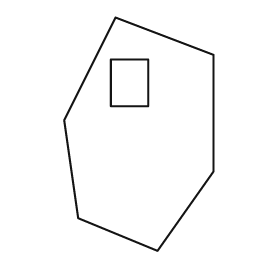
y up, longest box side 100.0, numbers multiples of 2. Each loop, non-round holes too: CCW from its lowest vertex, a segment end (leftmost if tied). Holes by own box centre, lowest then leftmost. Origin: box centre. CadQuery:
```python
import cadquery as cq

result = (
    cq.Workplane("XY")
    .moveTo(8.0, -50.0)
    .lineTo(32.0, -16.0)
    .lineTo(32.0, 34.0)
    .lineTo(-10.0, 50.0)
    .lineTo(-32.0, 6.0)
    .lineTo(-26.0, -36.0)
    .close()
    .moveTo(-12.0, 12.0)
    .lineTo(4.0, 12.0)
    .lineTo(4.0, 32.0)
    .lineTo(-12.0, 32.0)
    .close()
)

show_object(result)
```